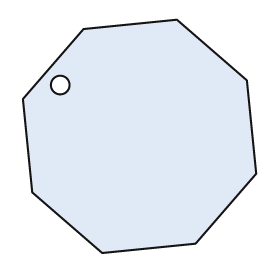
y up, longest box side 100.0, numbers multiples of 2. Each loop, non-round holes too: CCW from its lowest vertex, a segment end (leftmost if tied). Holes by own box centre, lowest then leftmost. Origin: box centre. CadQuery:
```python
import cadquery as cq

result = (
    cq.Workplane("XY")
    .moveTo(-16.0, -50.0)
    .lineTo(24.0, -46.0)
    .lineTo(50.0, -16.0)
    .lineTo(46.0, 24.0)
    .lineTo(16.0, 50.0)
    .lineTo(-24.0, 46.0)
    .lineTo(-50.0, 16.0)
    .lineTo(-46.0, -24.0)
    .close()
    .moveTo(-34.0, 22.0)
    .circle(4.0)
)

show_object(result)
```